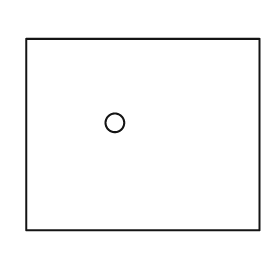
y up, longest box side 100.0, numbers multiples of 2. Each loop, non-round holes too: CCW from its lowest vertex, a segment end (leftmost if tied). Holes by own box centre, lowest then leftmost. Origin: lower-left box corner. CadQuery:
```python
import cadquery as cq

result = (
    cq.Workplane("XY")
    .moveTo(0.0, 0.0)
    .lineTo(100.0, 0.0)
    .lineTo(100.0, 82.0)
    .lineTo(0.0, 82.0)
    .close()
    .moveTo(38.0, 46.0)
    .circle(4.0)
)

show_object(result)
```